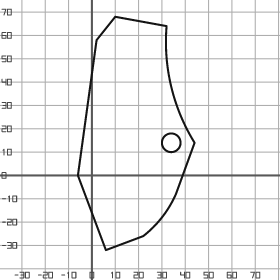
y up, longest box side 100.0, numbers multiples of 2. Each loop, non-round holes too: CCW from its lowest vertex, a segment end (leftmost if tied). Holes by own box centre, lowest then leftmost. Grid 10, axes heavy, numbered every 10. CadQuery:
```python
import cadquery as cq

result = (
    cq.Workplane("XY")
    .moveTo(6.0, -32.0)
    .lineTo(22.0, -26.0)
    .threePointArc((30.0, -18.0), (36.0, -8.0))
    .lineTo(44.0, 14.0)
    .threePointArc((34.0, 38.0), (32.0, 64.0))
    .lineTo(10.0, 68.0)
    .lineTo(2.0, 58.0)
    .lineTo(-6.0, 0.0)
    .close()
    .moveTo(34.0, 14.0)
    .circle(4.0)
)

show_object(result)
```